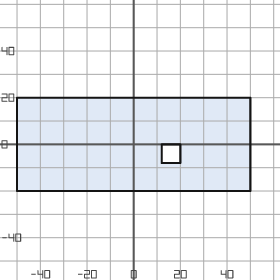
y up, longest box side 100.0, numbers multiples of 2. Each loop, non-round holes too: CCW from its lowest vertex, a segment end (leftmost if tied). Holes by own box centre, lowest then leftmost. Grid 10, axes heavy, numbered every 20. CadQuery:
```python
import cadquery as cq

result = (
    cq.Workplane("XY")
    .moveTo(-50.0, -20.0)
    .lineTo(50.0, -20.0)
    .lineTo(50.0, 20.0)
    .lineTo(-50.0, 20.0)
    .close()
    .moveTo(12.0, -8.0)
    .lineTo(20.0, -8.0)
    .lineTo(20.0, 0.0)
    .lineTo(12.0, 0.0)
    .close()
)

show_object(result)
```